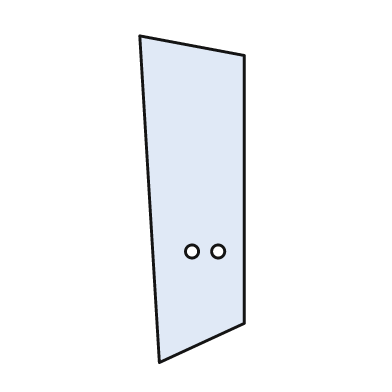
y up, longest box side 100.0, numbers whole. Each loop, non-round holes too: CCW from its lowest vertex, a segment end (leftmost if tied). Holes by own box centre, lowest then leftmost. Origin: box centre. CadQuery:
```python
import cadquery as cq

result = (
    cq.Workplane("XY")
    .moveTo(-10.0, -50.0)
    .lineTo(16.0, -38.0)
    .lineTo(16.0, 44.0)
    .lineTo(-16.0, 50.0)
    .close()
    .moveTo(0.0, -16.0)
    .circle(2.0)
    .moveTo(8.0, -16.0)
    .circle(2.0)
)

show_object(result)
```